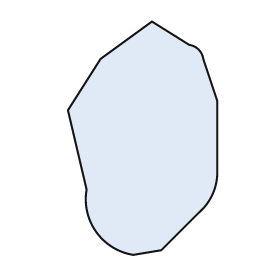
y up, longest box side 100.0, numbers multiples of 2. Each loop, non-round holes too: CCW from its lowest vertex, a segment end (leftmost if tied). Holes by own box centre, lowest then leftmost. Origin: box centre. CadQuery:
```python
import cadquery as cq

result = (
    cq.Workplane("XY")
    .moveTo(-4.0, -50.0)
    .lineTo(8.0, -48.0)
    .lineTo(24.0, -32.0)
    .threePointArc((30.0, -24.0), (32.0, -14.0))
    .lineTo(32.0, 16.0)
    .lineTo(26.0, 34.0)
    .threePointArc((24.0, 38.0), (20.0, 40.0))
    .lineTo(4.0, 50.0)
    .lineTo(-18.0, 34.0)
    .lineTo(-32.0, 12.0)
    .lineTo(-24.0, -22.0)
    .threePointArc((-20.0, -40.0), (-4.0, -50.0))
    .close()
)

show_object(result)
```